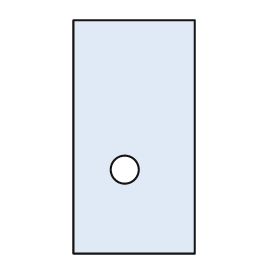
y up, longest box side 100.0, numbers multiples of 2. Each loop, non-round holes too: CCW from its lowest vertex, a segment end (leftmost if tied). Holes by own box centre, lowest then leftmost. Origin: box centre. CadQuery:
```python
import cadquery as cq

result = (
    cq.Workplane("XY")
    .moveTo(-26.0, -50.0)
    .lineTo(26.0, -50.0)
    .lineTo(26.0, 50.0)
    .lineTo(-26.0, 50.0)
    .close()
    .moveTo(-4.0, -14.0)
    .circle(6.0)
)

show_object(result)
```